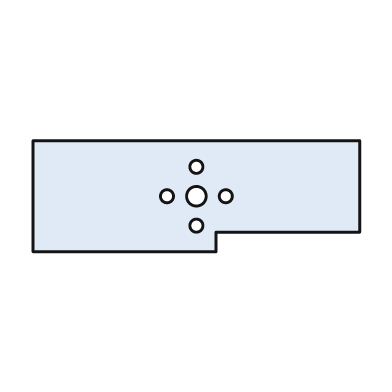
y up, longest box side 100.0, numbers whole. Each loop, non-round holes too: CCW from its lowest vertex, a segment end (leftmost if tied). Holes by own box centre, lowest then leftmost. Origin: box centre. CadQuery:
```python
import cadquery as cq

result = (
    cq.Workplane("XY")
    .moveTo(-50.0, -17.0)
    .lineTo(6.0, -17.0)
    .lineTo(6.0, -11.0)
    .lineTo(50.0, -11.0)
    .lineTo(50.0, 17.0)
    .lineTo(-50.0, 17.0)
    .close()
    .moveTo(0.0, -9.0)
    .circle(2.0)
    .moveTo(-9.0, 0.0)
    .circle(2.0)
    .moveTo(0.0, 0.0)
    .circle(3.0)
    .moveTo(9.0, 0.0)
    .circle(2.0)
    .moveTo(0.0, 9.0)
    .circle(2.0)
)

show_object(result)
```